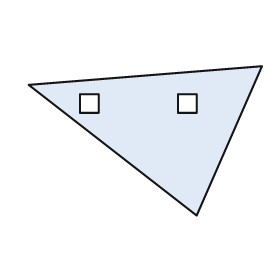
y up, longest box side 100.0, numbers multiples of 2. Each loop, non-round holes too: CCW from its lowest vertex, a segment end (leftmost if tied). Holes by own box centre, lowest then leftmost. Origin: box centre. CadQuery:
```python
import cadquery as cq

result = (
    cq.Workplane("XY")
    .moveTo(22.0, -32.0)
    .lineTo(50.0, 32.0)
    .lineTo(-50.0, 24.0)
    .close()
    .moveTo(-28.0, 12.0)
    .lineTo(-20.0, 12.0)
    .lineTo(-20.0, 20.0)
    .lineTo(-28.0, 20.0)
    .close()
    .moveTo(14.0, 12.0)
    .lineTo(22.0, 12.0)
    .lineTo(22.0, 20.0)
    .lineTo(14.0, 20.0)
    .close()
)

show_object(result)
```